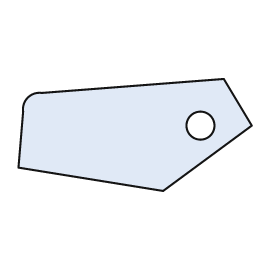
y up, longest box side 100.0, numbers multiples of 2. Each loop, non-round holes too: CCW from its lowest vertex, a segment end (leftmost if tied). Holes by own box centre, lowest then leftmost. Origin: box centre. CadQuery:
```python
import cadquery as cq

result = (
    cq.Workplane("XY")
    .moveTo(12.0, -24.0)
    .lineTo(50.0, 4.0)
    .lineTo(38.0, 24.0)
    .lineTo(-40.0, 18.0)
    .threePointArc((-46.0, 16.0), (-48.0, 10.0))
    .lineTo(-50.0, -14.0)
    .close()
    .moveTo(28.0, 4.0)
    .circle(6.0)
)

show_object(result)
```